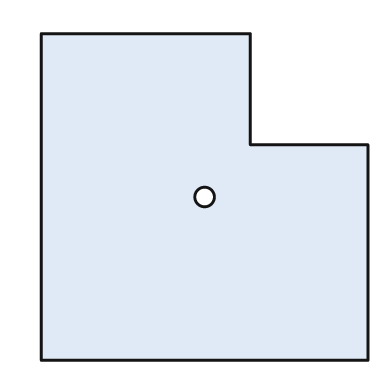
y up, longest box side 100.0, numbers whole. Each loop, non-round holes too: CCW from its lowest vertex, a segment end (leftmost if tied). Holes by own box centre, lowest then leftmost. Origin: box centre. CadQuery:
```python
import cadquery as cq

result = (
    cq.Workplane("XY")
    .moveTo(-50.0, -50.0)
    .lineTo(50.0, -50.0)
    .lineTo(50.0, 16.0)
    .lineTo(14.0, 16.0)
    .lineTo(14.0, 50.0)
    .lineTo(-50.0, 50.0)
    .close()
    .moveTo(0.0, 0.0)
    .circle(3.0)
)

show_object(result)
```